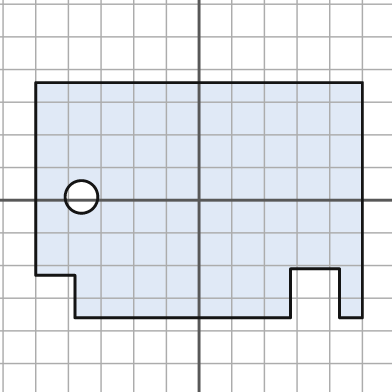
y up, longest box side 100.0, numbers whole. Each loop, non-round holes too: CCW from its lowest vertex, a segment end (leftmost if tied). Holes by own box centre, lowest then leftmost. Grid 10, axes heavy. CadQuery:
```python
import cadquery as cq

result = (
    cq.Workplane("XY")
    .moveTo(-38.0, -36.0)
    .lineTo(28.0, -36.0)
    .lineTo(28.0, -21.0)
    .lineTo(43.0, -21.0)
    .lineTo(43.0, -36.0)
    .lineTo(50.0, -36.0)
    .lineTo(50.0, 36.0)
    .lineTo(-50.0, 36.0)
    .lineTo(-50.0, -23.0)
    .lineTo(-38.0, -23.0)
    .close()
    .moveTo(-36.0, 1.0)
    .circle(5.0)
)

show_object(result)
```